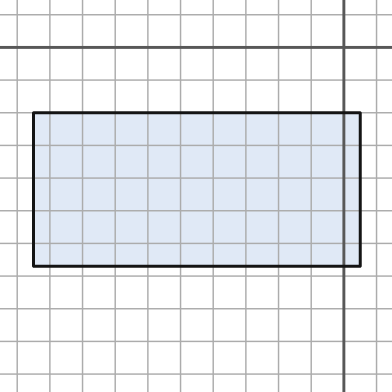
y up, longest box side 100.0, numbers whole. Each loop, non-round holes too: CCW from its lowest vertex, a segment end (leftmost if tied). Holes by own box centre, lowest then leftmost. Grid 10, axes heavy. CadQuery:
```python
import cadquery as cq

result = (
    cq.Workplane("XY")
    .moveTo(-95.0, -67.0)
    .lineTo(5.0, -67.0)
    .lineTo(5.0, -20.0)
    .lineTo(-95.0, -20.0)
    .close()
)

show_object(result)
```